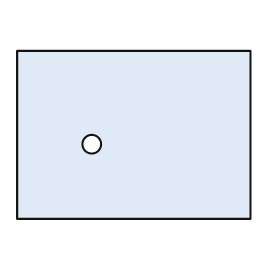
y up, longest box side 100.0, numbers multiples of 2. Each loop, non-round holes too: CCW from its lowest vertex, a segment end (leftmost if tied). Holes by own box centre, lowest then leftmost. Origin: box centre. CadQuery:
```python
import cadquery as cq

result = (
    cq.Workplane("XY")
    .moveTo(-50.0, -36.0)
    .lineTo(50.0, -36.0)
    .lineTo(50.0, 36.0)
    .lineTo(-50.0, 36.0)
    .close()
    .moveTo(-18.0, -4.0)
    .circle(4.0)
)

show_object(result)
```